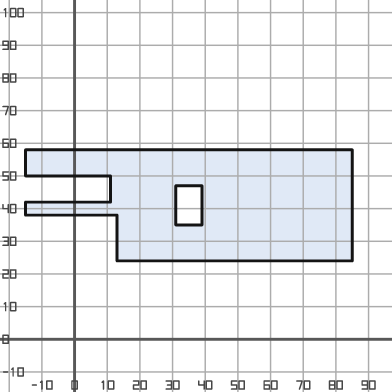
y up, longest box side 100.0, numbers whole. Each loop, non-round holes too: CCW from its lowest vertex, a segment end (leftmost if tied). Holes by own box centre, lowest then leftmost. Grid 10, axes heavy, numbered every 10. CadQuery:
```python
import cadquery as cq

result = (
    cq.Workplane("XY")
    .moveTo(13.0, 24.0)
    .lineTo(85.0, 24.0)
    .lineTo(85.0, 58.0)
    .lineTo(-15.0, 58.0)
    .lineTo(-15.0, 50.0)
    .lineTo(11.0, 50.0)
    .lineTo(11.0, 42.0)
    .lineTo(-15.0, 42.0)
    .lineTo(-15.0, 38.0)
    .lineTo(13.0, 38.0)
    .close()
    .moveTo(31.0, 35.0)
    .lineTo(39.0, 35.0)
    .lineTo(39.0, 47.0)
    .lineTo(31.0, 47.0)
    .close()
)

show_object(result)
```